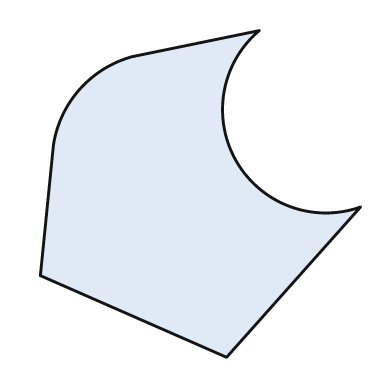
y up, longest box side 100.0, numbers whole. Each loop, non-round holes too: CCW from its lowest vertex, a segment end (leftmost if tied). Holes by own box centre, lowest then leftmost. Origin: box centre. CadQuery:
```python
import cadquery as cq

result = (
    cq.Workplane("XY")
    .moveTo(8.0, -50.0)
    .lineTo(49.0, -4.0)
    .threePointArc((11.0, 10.0), (18.0, 50.0))
    .lineTo(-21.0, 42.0)
    .threePointArc((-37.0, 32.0), (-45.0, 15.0))
    .lineTo(-49.0, -25.0)
    .close()
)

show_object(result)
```